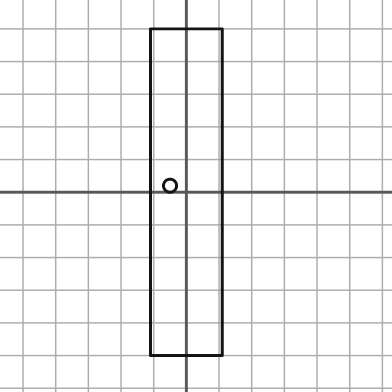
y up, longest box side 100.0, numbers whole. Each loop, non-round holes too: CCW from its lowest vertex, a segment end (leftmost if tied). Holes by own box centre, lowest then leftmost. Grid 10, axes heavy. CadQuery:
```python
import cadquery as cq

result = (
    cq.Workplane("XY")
    .moveTo(-11.0, -50.0)
    .lineTo(11.0, -50.0)
    .lineTo(11.0, 50.0)
    .lineTo(-11.0, 50.0)
    .close()
    .moveTo(-5.0, 2.0)
    .circle(2.0)
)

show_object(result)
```